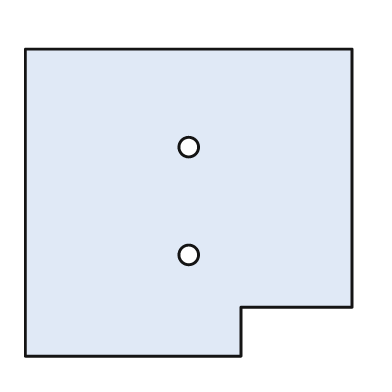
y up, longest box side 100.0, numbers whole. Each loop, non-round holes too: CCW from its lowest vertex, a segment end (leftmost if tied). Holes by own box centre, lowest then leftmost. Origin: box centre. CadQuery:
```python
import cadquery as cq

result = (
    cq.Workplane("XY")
    .moveTo(-50.0, -47.0)
    .lineTo(16.0, -47.0)
    .lineTo(16.0, -32.0)
    .lineTo(50.0, -32.0)
    .lineTo(50.0, 47.0)
    .lineTo(-50.0, 47.0)
    .close()
    .moveTo(0.0, -16.0)
    .circle(3.0)
    .moveTo(0.0, 17.0)
    .circle(3.0)
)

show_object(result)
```